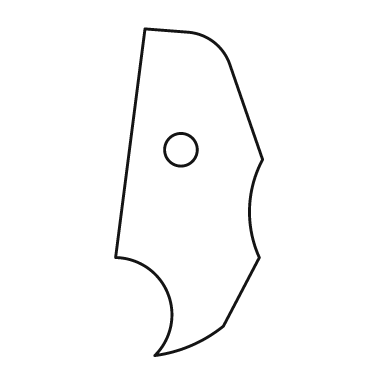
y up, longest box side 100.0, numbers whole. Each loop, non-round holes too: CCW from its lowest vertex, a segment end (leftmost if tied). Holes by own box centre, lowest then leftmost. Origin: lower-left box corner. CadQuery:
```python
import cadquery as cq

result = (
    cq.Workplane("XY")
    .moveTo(12.0, 0.0)
    .threePointArc((23.0, 3.0), (33.0, 9.0))
    .lineTo(44.0, 30.0)
    .threePointArc((41.0, 45.0), (45.0, 60.0))
    .lineTo(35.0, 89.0)
    .threePointArc((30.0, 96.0), (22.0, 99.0))
    .lineTo(9.0, 100.0)
    .lineTo(0.0, 30.0)
    .threePointArc((16.0, 19.0), (12.0, 0.0))
    .close()
    .moveTo(20.0, 63.0)
    .circle(5.0)
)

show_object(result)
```